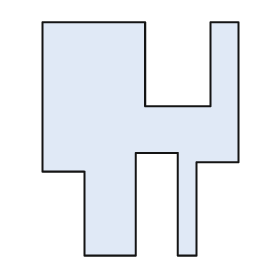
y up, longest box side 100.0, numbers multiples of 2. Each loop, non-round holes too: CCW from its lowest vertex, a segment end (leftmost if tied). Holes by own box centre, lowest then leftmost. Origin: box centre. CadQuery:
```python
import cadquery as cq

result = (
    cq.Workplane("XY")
    .moveTo(-24.0, -50.0)
    .lineTo(-2.0, -50.0)
    .lineTo(-2.0, -6.0)
    .lineTo(16.0, -6.0)
    .lineTo(16.0, -50.0)
    .lineTo(24.0, -50.0)
    .lineTo(24.0, -10.0)
    .lineTo(42.0, -10.0)
    .lineTo(42.0, 50.0)
    .lineTo(30.0, 50.0)
    .lineTo(30.0, 14.0)
    .lineTo(2.0, 14.0)
    .lineTo(2.0, 50.0)
    .lineTo(-42.0, 50.0)
    .lineTo(-42.0, -14.0)
    .lineTo(-24.0, -14.0)
    .close()
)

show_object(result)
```